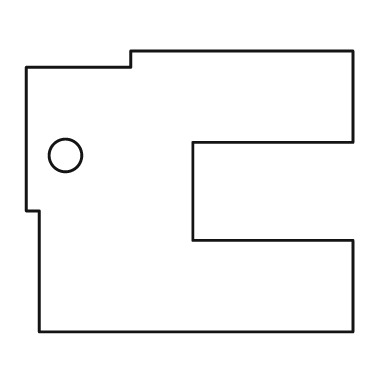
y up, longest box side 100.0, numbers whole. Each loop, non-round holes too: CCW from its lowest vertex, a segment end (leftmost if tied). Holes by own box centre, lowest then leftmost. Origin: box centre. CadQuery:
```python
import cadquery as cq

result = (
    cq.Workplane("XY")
    .moveTo(-46.0, -43.0)
    .lineTo(50.0, -43.0)
    .lineTo(50.0, -15.0)
    .lineTo(1.0, -15.0)
    .lineTo(1.0, 15.0)
    .lineTo(50.0, 15.0)
    .lineTo(50.0, 43.0)
    .lineTo(-18.0, 43.0)
    .lineTo(-18.0, 38.0)
    .lineTo(-50.0, 38.0)
    .lineTo(-50.0, -6.0)
    .lineTo(-46.0, -6.0)
    .close()
    .moveTo(-38.0, 11.0)
    .circle(5.0)
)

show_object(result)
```